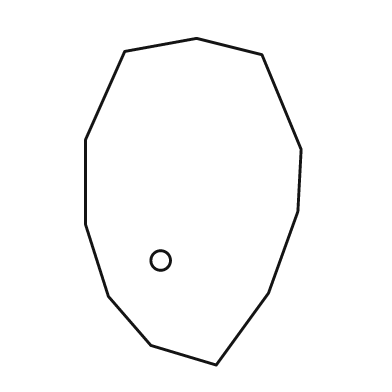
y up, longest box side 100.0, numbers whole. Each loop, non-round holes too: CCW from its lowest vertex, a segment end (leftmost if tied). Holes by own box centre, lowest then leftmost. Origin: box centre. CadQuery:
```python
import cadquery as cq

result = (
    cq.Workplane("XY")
    .moveTo(7.0, -50.0)
    .lineTo(23.0, -28.0)
    .lineTo(32.0, -3.0)
    .lineTo(33.0, 16.0)
    .lineTo(21.0, 45.0)
    .lineTo(1.0, 50.0)
    .lineTo(-21.0, 46.0)
    .lineTo(-33.0, 19.0)
    .lineTo(-33.0, -7.0)
    .lineTo(-26.0, -29.0)
    .lineTo(-13.0, -44.0)
    .close()
    .moveTo(-10.0, -18.0)
    .circle(3.0)
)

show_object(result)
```